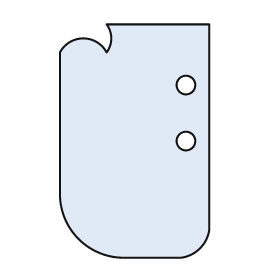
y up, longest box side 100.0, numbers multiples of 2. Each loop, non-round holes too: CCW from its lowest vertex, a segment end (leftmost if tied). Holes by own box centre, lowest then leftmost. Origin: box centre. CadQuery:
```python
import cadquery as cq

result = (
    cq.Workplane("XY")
    .moveTo(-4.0, -50.0)
    .lineTo(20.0, -50.0)
    .threePointArc((28.0, -46.0), (32.0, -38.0))
    .lineTo(32.0, 50.0)
    .lineTo(-12.0, 50.0)
    .threePointArc((-10.0, 44.0), (-12.0, 38.0))
    .threePointArc((-22.0, 44.0), (-32.0, 38.0))
    .lineTo(-32.0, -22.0)
    .threePointArc((-24.0, -42.0), (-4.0, -50.0))
    .close()
    .moveTo(22.0, 0.0)
    .circle(4.0)
    .moveTo(22.0, 24.0)
    .circle(4.0)
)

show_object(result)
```